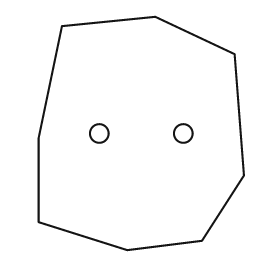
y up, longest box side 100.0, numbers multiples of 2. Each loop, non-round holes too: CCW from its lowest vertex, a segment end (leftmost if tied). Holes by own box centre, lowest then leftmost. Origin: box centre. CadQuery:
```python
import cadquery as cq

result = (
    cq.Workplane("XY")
    .moveTo(-6.0, -50.0)
    .lineTo(26.0, -46.0)
    .lineTo(44.0, -18.0)
    .lineTo(40.0, 34.0)
    .lineTo(6.0, 50.0)
    .lineTo(-34.0, 46.0)
    .lineTo(-44.0, -2.0)
    .lineTo(-44.0, -38.0)
    .close()
    .moveTo(-18.0, 0.0)
    .circle(4.0)
    .moveTo(18.0, 0.0)
    .circle(4.0)
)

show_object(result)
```